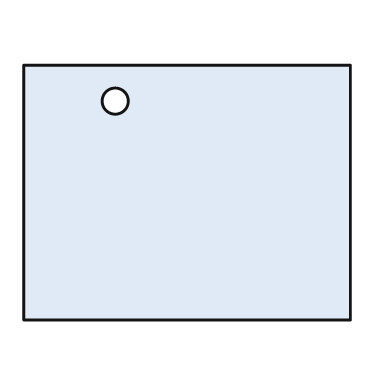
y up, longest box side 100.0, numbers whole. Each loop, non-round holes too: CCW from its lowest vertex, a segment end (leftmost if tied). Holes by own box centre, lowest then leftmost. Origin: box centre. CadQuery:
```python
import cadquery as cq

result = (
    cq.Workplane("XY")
    .moveTo(-50.0, -39.0)
    .lineTo(50.0, -39.0)
    .lineTo(50.0, 39.0)
    .lineTo(-50.0, 39.0)
    .close()
    .moveTo(-22.0, 28.0)
    .circle(4.0)
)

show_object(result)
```